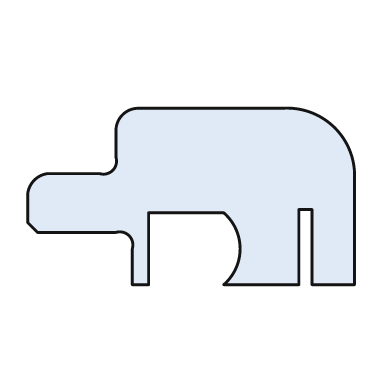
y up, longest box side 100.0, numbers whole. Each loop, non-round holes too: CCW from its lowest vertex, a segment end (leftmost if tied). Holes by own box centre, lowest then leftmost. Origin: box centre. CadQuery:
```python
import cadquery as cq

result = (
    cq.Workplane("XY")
    .moveTo(-18.0, -27.0)
    .lineTo(-13.0, -27.0)
    .lineTo(-13.0, -5.0)
    .lineTo(10.0, -5.0)
    .threePointArc((15.0, -16.0), (10.0, -27.0))
    .lineTo(33.0, -27.0)
    .lineTo(33.0, -4.0)
    .lineTo(37.0, -4.0)
    .lineTo(37.0, -27.0)
    .lineTo(50.0, -27.0)
    .lineTo(50.0, 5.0)
    .threePointArc((44.0, 21.0), (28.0, 27.0))
    .lineTo(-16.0, 27.0)
    .threePointArc((-21.0, 25.0), (-23.0, 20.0))
    .lineTo(-23.0, 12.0)
    .threePointArc((-24.0, 8.0), (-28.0, 7.0))
    .lineTo(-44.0, 7.0)
    .threePointArc((-48.0, 5.0), (-50.0, 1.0))
    .lineTo(-50.0, -8.0)
    .lineTo(-47.0, -11.0)
    .lineTo(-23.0, -11.0)
    .threePointArc((-19.0, -12.0), (-18.0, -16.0))
    .close()
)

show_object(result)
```